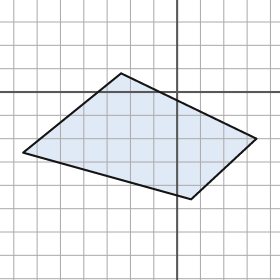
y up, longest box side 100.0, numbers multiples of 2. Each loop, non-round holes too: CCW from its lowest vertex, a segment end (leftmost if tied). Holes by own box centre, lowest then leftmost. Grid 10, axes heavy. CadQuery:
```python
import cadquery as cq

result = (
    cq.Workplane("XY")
    .moveTo(6.0, -46.0)
    .lineTo(34.0, -20.0)
    .lineTo(-24.0, 8.0)
    .lineTo(-66.0, -26.0)
    .close()
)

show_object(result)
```